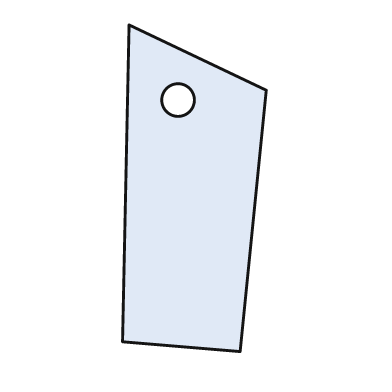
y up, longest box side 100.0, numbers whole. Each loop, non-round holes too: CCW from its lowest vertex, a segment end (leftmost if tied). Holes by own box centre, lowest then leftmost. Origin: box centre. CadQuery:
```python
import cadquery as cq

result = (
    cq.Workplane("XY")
    .moveTo(14.0, -50.0)
    .lineTo(22.0, 30.0)
    .lineTo(-20.0, 50.0)
    .lineTo(-22.0, -47.0)
    .close()
    .moveTo(-5.0, 27.0)
    .circle(5.0)
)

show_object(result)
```